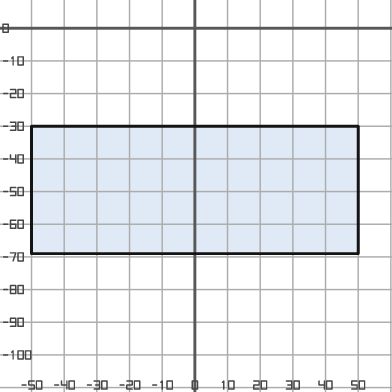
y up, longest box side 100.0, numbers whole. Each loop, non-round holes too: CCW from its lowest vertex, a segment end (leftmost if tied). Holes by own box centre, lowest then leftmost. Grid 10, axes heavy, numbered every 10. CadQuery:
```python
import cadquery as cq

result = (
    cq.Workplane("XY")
    .moveTo(-50.0, -69.0)
    .lineTo(50.0, -69.0)
    .lineTo(50.0, -30.0)
    .lineTo(-50.0, -30.0)
    .close()
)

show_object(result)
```